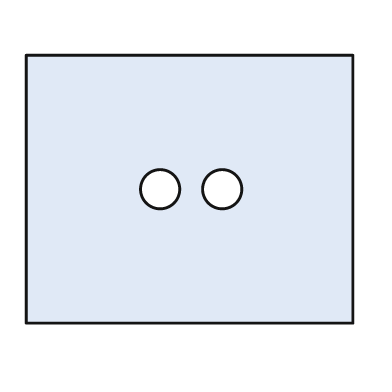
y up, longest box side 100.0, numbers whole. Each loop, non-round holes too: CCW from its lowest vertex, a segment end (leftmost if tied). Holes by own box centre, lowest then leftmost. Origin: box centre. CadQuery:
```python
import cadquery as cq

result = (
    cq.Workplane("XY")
    .moveTo(-50.0, -41.0)
    .lineTo(50.0, -41.0)
    .lineTo(50.0, 41.0)
    .lineTo(-50.0, 41.0)
    .close()
    .moveTo(-9.0, 0.0)
    .circle(6.0)
    .moveTo(10.0, 0.0)
    .circle(6.0)
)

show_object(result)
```